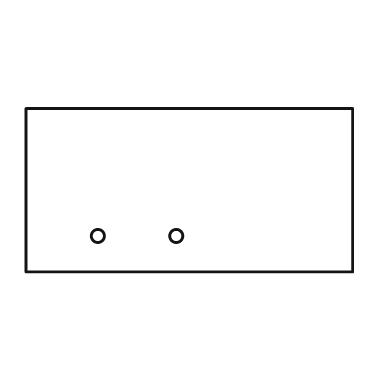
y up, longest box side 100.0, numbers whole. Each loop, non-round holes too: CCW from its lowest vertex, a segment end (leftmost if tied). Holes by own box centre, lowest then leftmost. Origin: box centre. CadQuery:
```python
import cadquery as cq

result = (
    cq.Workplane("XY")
    .moveTo(-50.0, -25.0)
    .lineTo(50.0, -25.0)
    .lineTo(50.0, 25.0)
    .lineTo(-50.0, 25.0)
    .close()
    .moveTo(-28.0, -14.0)
    .circle(2.0)
    .moveTo(-4.0, -14.0)
    .circle(2.0)
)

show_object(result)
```